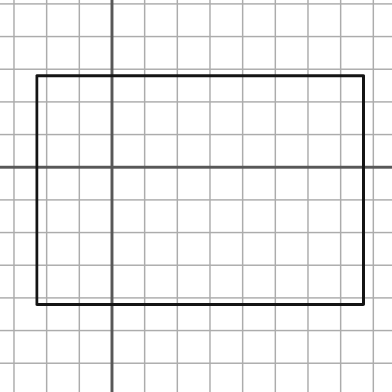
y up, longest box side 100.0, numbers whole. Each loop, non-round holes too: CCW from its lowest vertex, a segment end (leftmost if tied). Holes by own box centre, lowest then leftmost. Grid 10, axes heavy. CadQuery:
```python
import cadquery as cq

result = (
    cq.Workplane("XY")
    .moveTo(-23.0, -42.0)
    .lineTo(77.0, -42.0)
    .lineTo(77.0, 28.0)
    .lineTo(-23.0, 28.0)
    .close()
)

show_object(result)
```